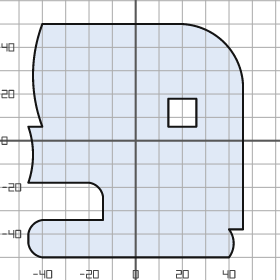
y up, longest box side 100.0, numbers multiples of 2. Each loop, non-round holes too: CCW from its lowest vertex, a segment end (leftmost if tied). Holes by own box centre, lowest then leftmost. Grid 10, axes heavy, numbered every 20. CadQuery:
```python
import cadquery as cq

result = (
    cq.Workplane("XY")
    .moveTo(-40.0, -50.0)
    .lineTo(40.0, -50.0)
    .threePointArc((42.0, -44.0), (40.0, -38.0))
    .lineTo(46.0, -38.0)
    .lineTo(46.0, 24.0)
    .threePointArc((38.0, 42.0), (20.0, 50.0))
    .lineTo(-40.0, 50.0)
    .threePointArc((-44.0, 28.0), (-40.0, 6.0))
    .lineTo(-46.0, 6.0)
    .threePointArc((-44.0, -6.0), (-46.0, -18.0))
    .lineTo(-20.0, -18.0)
    .threePointArc((-16.0, -20.0), (-14.0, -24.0))
    .lineTo(-14.0, -34.0)
    .lineTo(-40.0, -34.0)
    .threePointArc((-44.0, -36.0), (-46.0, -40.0))
    .lineTo(-46.0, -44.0)
    .threePointArc((-44.0, -48.0), (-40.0, -50.0))
    .close()
    .moveTo(14.0, 6.0)
    .lineTo(26.0, 6.0)
    .lineTo(26.0, 18.0)
    .lineTo(14.0, 18.0)
    .close()
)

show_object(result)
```